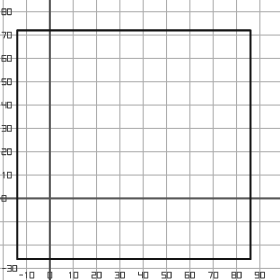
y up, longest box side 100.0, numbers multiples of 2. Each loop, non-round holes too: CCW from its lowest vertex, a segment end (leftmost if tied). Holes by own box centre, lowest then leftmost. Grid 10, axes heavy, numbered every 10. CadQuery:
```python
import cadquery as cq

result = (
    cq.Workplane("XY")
    .moveTo(-14.0, -26.0)
    .lineTo(86.0, -26.0)
    .lineTo(86.0, 72.0)
    .lineTo(-14.0, 72.0)
    .close()
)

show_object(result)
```